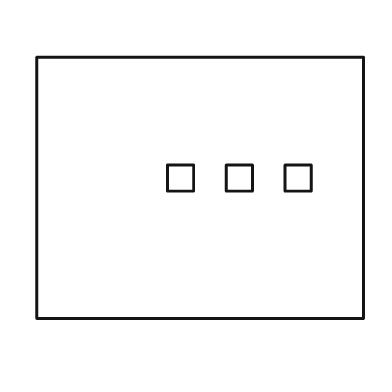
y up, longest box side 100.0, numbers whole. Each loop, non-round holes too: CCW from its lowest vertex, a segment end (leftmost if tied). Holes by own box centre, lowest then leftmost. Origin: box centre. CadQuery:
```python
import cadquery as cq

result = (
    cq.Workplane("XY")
    .moveTo(-50.0, -40.0)
    .lineTo(50.0, -40.0)
    .lineTo(50.0, 40.0)
    .lineTo(-50.0, 40.0)
    .close()
    .moveTo(-10.0, -1.0)
    .lineTo(-2.0, -1.0)
    .lineTo(-2.0, 7.0)
    .lineTo(-10.0, 7.0)
    .close()
    .moveTo(8.0, -1.0)
    .lineTo(16.0, -1.0)
    .lineTo(16.0, 7.0)
    .lineTo(8.0, 7.0)
    .close()
    .moveTo(26.0, -1.0)
    .lineTo(34.0, -1.0)
    .lineTo(34.0, 7.0)
    .lineTo(26.0, 7.0)
    .close()
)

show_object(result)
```